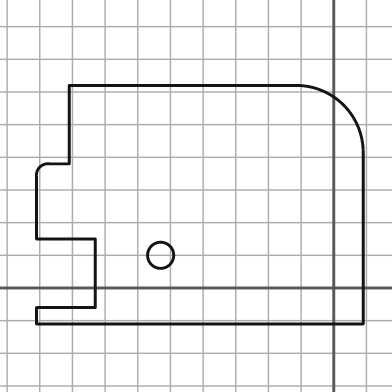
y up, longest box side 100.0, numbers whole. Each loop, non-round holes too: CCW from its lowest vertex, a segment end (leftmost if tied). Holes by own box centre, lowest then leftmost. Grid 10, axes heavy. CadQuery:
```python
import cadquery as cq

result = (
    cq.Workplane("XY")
    .moveTo(-91.0, -11.0)
    .lineTo(9.0, -11.0)
    .lineTo(9.0, 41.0)
    .threePointArc((3.0, 56.0), (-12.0, 62.0))
    .lineTo(-81.0, 62.0)
    .lineTo(-81.0, 38.0)
    .lineTo(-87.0, 38.0)
    .threePointArc((-90.0, 37.0), (-91.0, 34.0))
    .lineTo(-91.0, 15.0)
    .lineTo(-73.0, 15.0)
    .lineTo(-73.0, -6.0)
    .lineTo(-91.0, -6.0)
    .close()
    .moveTo(-53.0, 10.0)
    .circle(4.0)
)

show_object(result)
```